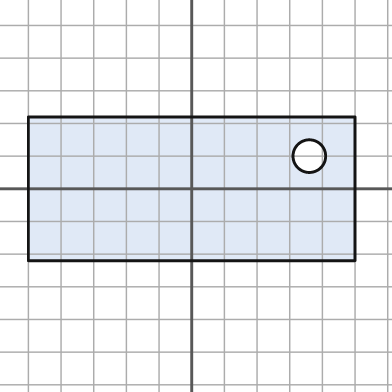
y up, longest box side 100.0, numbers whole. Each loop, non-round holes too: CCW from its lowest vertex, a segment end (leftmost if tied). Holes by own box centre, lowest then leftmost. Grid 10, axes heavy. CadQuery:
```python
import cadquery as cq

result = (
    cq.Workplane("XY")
    .moveTo(-50.0, -22.0)
    .lineTo(50.0, -22.0)
    .lineTo(50.0, 22.0)
    .lineTo(-50.0, 22.0)
    .close()
    .moveTo(36.0, 10.0)
    .circle(5.0)
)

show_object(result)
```